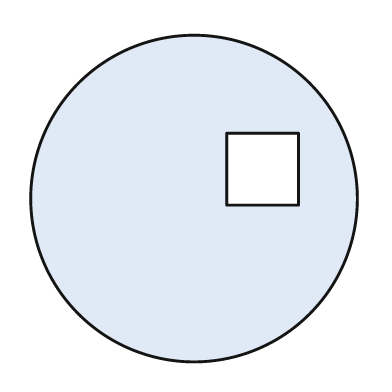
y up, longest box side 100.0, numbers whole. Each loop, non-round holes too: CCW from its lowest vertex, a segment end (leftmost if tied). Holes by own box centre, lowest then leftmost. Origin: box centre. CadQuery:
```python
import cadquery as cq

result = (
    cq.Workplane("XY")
    .moveTo(0.0, 0.0)
    .circle(50.0)
    .moveTo(10.0, -2.0)
    .lineTo(32.0, -2.0)
    .lineTo(32.0, 20.0)
    .lineTo(10.0, 20.0)
    .close()
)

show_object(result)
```